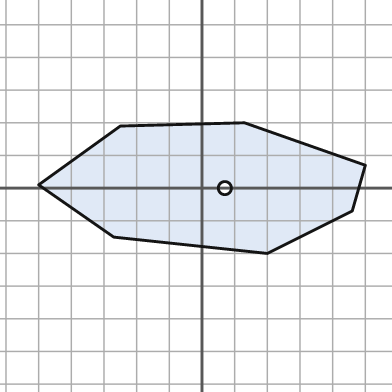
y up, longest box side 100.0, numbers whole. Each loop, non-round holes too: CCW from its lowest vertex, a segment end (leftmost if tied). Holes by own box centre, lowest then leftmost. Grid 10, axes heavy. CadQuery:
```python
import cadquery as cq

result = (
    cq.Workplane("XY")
    .moveTo(20.0, -20.0)
    .lineTo(46.0, -7.0)
    .lineTo(50.0, 7.0)
    .lineTo(13.0, 20.0)
    .lineTo(-25.0, 19.0)
    .lineTo(-50.0, 1.0)
    .lineTo(-27.0, -15.0)
    .close()
    .moveTo(7.0, 0.0)
    .circle(2.0)
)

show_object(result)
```